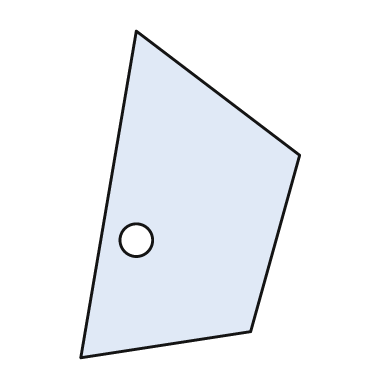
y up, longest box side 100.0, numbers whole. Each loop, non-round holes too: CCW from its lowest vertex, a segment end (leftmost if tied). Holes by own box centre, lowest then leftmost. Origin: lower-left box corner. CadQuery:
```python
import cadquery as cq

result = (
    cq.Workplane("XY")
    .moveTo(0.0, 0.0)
    .lineTo(52.0, 8.0)
    .lineTo(67.0, 62.0)
    .lineTo(17.0, 100.0)
    .close()
    .moveTo(17.0, 36.0)
    .circle(5.0)
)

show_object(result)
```